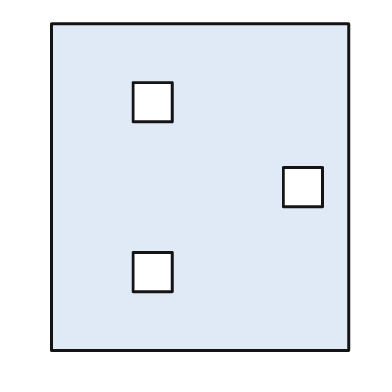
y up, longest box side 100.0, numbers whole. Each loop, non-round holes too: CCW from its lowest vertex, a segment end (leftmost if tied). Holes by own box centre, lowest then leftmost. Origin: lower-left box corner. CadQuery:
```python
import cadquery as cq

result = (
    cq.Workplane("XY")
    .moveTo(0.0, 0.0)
    .lineTo(91.0, 0.0)
    .lineTo(91.0, 100.0)
    .lineTo(0.0, 100.0)
    .close()
    .moveTo(25.0, 18.0)
    .lineTo(37.0, 18.0)
    .lineTo(37.0, 30.0)
    .lineTo(25.0, 30.0)
    .close()
    .moveTo(71.0, 44.0)
    .lineTo(83.0, 44.0)
    .lineTo(83.0, 56.0)
    .lineTo(71.0, 56.0)
    .close()
    .moveTo(25.0, 70.0)
    .lineTo(37.0, 70.0)
    .lineTo(37.0, 82.0)
    .lineTo(25.0, 82.0)
    .close()
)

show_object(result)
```